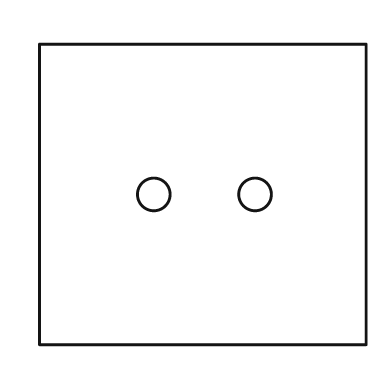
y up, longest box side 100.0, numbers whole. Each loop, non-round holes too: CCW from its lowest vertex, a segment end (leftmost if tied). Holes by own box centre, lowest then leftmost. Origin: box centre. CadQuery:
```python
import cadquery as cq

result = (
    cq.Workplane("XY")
    .moveTo(-50.0, -46.0)
    .lineTo(50.0, -46.0)
    .lineTo(50.0, 46.0)
    .lineTo(-50.0, 46.0)
    .close()
    .moveTo(-15.0, 0.0)
    .circle(5.0)
    .moveTo(16.0, 0.0)
    .circle(5.0)
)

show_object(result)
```